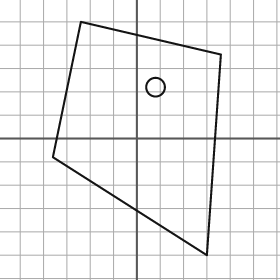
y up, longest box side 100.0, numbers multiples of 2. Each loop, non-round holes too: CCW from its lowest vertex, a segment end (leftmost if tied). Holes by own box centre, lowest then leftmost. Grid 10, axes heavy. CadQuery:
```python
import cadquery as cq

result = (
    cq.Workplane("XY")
    .moveTo(30.0, -50.0)
    .lineTo(36.0, 36.0)
    .lineTo(-24.0, 50.0)
    .lineTo(-36.0, -8.0)
    .close()
    .moveTo(8.0, 22.0)
    .circle(4.0)
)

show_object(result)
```